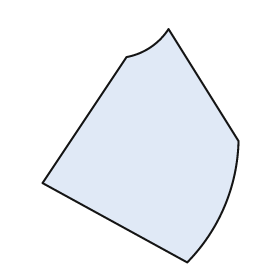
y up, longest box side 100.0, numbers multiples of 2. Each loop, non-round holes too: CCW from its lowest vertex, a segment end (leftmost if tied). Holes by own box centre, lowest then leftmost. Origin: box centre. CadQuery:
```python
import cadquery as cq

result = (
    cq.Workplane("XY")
    .moveTo(20.0, -50.0)
    .threePointArc((36.0, -26.0), (42.0, 2.0))
    .lineTo(12.0, 50.0)
    .threePointArc((4.0, 42.0), (-6.0, 38.0))
    .lineTo(-42.0, -16.0)
    .close()
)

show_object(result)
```